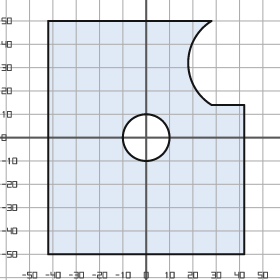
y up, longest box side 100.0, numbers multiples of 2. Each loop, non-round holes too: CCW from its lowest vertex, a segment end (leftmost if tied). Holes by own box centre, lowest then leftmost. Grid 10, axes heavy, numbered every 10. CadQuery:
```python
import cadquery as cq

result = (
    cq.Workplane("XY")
    .moveTo(-42.0, -50.0)
    .lineTo(42.0, -50.0)
    .lineTo(42.0, 14.0)
    .lineTo(28.0, 14.0)
    .threePointArc((18.0, 32.0), (28.0, 50.0))
    .lineTo(-42.0, 50.0)
    .close()
    .moveTo(0.0, 0.0)
    .circle(10.0)
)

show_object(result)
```